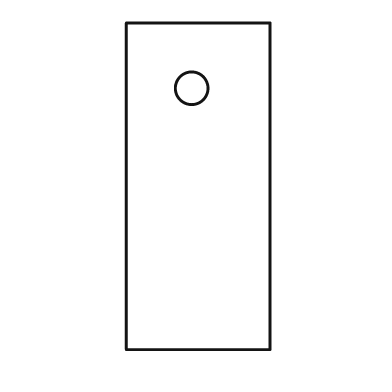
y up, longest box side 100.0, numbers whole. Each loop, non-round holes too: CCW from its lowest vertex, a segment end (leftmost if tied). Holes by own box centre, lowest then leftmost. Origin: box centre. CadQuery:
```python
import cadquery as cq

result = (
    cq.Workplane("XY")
    .moveTo(-22.0, -50.0)
    .lineTo(22.0, -50.0)
    .lineTo(22.0, 50.0)
    .lineTo(-22.0, 50.0)
    .close()
    .moveTo(-2.0, 30.0)
    .circle(5.0)
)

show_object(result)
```